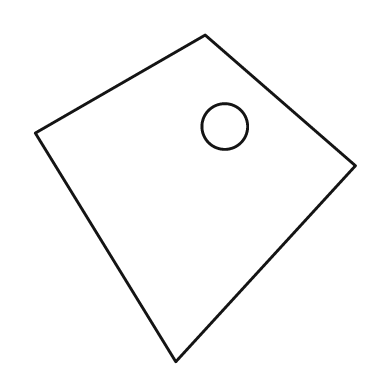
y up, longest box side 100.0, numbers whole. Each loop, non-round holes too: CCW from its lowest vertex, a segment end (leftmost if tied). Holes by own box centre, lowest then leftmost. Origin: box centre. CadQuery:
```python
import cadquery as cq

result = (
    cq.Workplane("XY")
    .moveTo(-6.0, -50.0)
    .lineTo(49.0, 10.0)
    .lineTo(3.0, 50.0)
    .lineTo(-49.0, 20.0)
    .close()
    .moveTo(9.0, 22.0)
    .circle(7.0)
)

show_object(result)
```